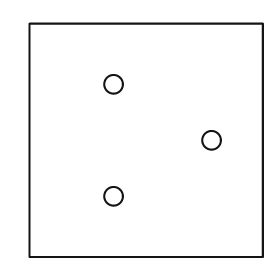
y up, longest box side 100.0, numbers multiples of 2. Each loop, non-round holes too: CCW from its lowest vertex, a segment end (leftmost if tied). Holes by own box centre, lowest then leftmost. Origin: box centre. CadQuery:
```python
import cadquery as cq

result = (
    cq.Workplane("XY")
    .moveTo(-50.0, -50.0)
    .lineTo(50.0, -50.0)
    .lineTo(50.0, 50.0)
    .lineTo(-50.0, 50.0)
    .close()
    .moveTo(-14.0, -24.0)
    .circle(4.0)
    .moveTo(28.0, 0.0)
    .circle(4.0)
    .moveTo(-14.0, 24.0)
    .circle(4.0)
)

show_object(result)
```